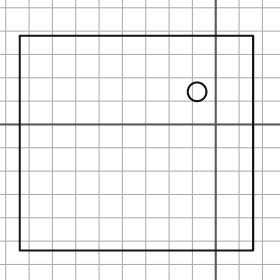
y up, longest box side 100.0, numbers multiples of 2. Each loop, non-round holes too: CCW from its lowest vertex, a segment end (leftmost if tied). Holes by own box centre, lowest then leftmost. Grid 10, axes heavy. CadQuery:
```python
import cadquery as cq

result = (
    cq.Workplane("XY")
    .moveTo(-84.0, -54.0)
    .lineTo(16.0, -54.0)
    .lineTo(16.0, 38.0)
    .lineTo(-84.0, 38.0)
    .close()
    .moveTo(-8.0, 14.0)
    .circle(4.0)
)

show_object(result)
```